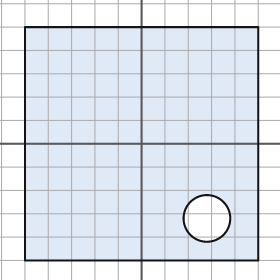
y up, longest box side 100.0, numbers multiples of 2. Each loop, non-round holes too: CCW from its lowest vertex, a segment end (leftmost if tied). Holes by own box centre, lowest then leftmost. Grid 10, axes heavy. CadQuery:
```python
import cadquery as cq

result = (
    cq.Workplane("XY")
    .moveTo(-50.0, -50.0)
    .lineTo(50.0, -50.0)
    .lineTo(50.0, 50.0)
    .lineTo(-50.0, 50.0)
    .close()
    .moveTo(28.0, -32.0)
    .circle(10.0)
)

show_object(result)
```